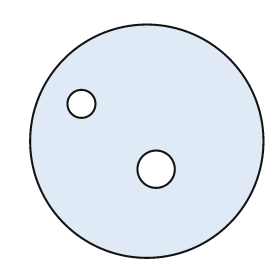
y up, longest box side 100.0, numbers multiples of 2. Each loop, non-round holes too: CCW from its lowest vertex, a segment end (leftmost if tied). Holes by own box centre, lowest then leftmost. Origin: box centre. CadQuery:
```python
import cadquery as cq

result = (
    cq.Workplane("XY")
    .moveTo(0.0, 0.0)
    .circle(50.0)
    .moveTo(4.0, -12.0)
    .circle(8.0)
    .moveTo(-28.0, 16.0)
    .circle(6.0)
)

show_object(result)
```